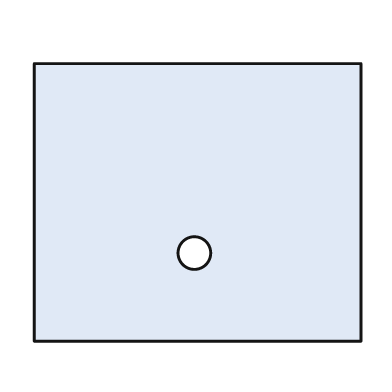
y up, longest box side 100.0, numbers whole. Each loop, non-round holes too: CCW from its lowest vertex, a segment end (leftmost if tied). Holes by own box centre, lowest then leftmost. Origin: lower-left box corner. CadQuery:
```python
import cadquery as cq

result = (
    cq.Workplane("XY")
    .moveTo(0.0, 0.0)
    .lineTo(100.0, 0.0)
    .lineTo(100.0, 85.0)
    .lineTo(0.0, 85.0)
    .close()
    .moveTo(49.0, 27.0)
    .circle(5.0)
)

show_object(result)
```